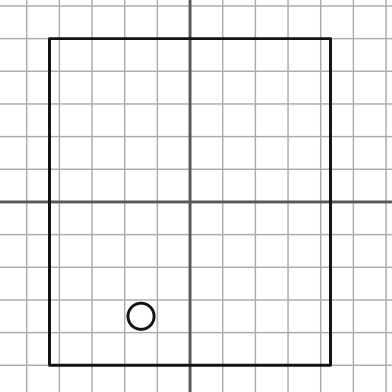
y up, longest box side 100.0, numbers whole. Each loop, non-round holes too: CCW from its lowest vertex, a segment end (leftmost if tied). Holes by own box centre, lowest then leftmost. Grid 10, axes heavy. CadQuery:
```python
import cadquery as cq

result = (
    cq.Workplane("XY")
    .moveTo(-43.0, -50.0)
    .lineTo(43.0, -50.0)
    .lineTo(43.0, 50.0)
    .lineTo(-43.0, 50.0)
    .close()
    .moveTo(-15.0, -35.0)
    .circle(4.0)
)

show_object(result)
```